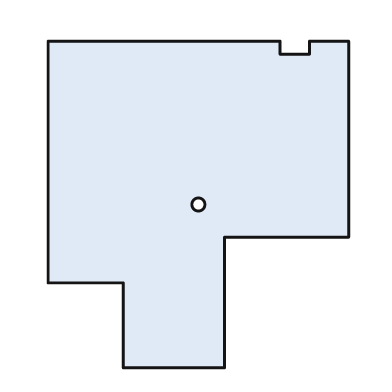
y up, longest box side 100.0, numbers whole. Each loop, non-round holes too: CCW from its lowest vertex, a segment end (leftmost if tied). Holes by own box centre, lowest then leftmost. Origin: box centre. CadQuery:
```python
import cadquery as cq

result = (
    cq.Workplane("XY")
    .moveTo(-23.0, -50.0)
    .lineTo(8.0, -50.0)
    .lineTo(8.0, -10.0)
    .lineTo(46.0, -10.0)
    .lineTo(46.0, 50.0)
    .lineTo(34.0, 50.0)
    .lineTo(34.0, 46.0)
    .lineTo(25.0, 46.0)
    .lineTo(25.0, 50.0)
    .lineTo(-46.0, 50.0)
    .lineTo(-46.0, -24.0)
    .lineTo(-23.0, -24.0)
    .close()
    .moveTo(0.0, 0.0)
    .circle(2.0)
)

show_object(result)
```